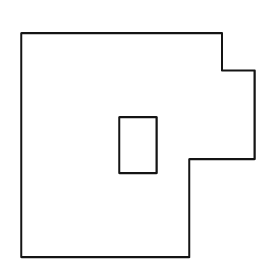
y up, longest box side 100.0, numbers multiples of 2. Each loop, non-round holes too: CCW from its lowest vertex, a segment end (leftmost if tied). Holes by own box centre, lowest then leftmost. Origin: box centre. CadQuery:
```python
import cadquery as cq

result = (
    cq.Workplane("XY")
    .moveTo(-50.0, -48.0)
    .lineTo(22.0, -48.0)
    .lineTo(22.0, -6.0)
    .lineTo(50.0, -6.0)
    .lineTo(50.0, 32.0)
    .lineTo(36.0, 32.0)
    .lineTo(36.0, 48.0)
    .lineTo(-50.0, 48.0)
    .close()
    .moveTo(-8.0, -12.0)
    .lineTo(8.0, -12.0)
    .lineTo(8.0, 12.0)
    .lineTo(-8.0, 12.0)
    .close()
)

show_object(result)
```